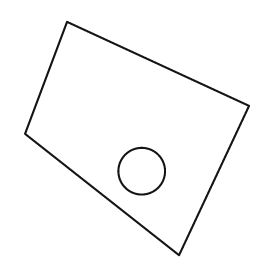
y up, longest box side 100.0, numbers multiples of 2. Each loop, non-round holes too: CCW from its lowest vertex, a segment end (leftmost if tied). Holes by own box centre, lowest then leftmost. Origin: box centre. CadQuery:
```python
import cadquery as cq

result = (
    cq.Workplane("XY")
    .moveTo(18.0, -50.0)
    .lineTo(48.0, 14.0)
    .lineTo(-30.0, 50.0)
    .lineTo(-48.0, 2.0)
    .close()
    .moveTo(2.0, -14.0)
    .circle(10.0)
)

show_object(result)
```